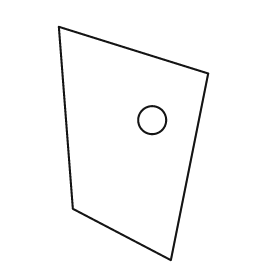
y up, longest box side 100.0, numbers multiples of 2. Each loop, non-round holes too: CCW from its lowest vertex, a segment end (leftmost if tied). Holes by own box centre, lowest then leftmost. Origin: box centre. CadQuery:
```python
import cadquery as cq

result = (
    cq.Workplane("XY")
    .moveTo(16.0, -50.0)
    .lineTo(32.0, 30.0)
    .lineTo(-32.0, 50.0)
    .lineTo(-26.0, -28.0)
    .close()
    .moveTo(8.0, 10.0)
    .circle(6.0)
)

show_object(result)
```